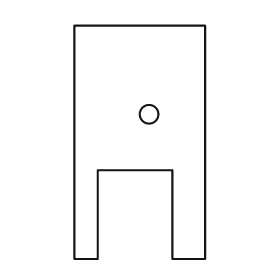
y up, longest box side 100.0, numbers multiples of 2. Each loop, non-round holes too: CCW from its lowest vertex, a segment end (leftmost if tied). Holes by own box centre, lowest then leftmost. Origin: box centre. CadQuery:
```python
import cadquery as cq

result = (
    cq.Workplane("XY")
    .moveTo(-28.0, -50.0)
    .lineTo(-18.0, -50.0)
    .lineTo(-18.0, -12.0)
    .lineTo(14.0, -12.0)
    .lineTo(14.0, -50.0)
    .lineTo(28.0, -50.0)
    .lineTo(28.0, 50.0)
    .lineTo(-28.0, 50.0)
    .close()
    .moveTo(4.0, 12.0)
    .circle(4.0)
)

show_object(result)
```